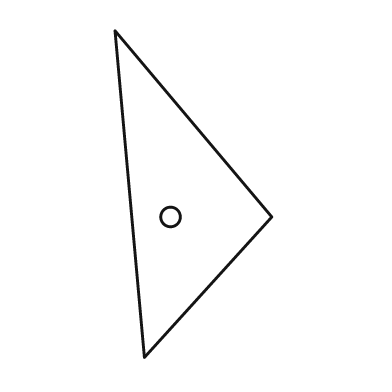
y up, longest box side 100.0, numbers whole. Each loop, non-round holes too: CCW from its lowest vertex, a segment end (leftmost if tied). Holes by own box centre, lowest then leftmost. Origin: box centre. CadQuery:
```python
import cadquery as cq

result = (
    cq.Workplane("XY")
    .moveTo(-15.0, -50.0)
    .lineTo(24.0, -7.0)
    .lineTo(-24.0, 50.0)
    .close()
    .moveTo(-7.0, -7.0)
    .circle(3.0)
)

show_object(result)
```